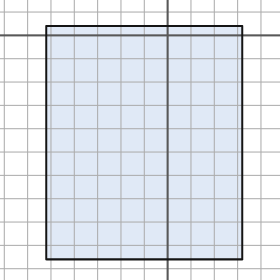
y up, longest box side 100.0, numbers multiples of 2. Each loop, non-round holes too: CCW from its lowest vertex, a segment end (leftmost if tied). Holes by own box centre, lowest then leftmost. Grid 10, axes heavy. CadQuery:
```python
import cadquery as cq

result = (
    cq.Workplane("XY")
    .moveTo(-52.0, -96.0)
    .lineTo(32.0, -96.0)
    .lineTo(32.0, 4.0)
    .lineTo(-52.0, 4.0)
    .close()
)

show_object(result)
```